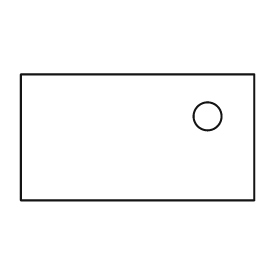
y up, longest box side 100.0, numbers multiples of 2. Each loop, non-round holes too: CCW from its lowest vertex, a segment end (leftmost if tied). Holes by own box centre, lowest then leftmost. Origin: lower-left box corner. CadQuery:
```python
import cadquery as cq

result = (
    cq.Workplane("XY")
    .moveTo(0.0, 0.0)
    .lineTo(100.0, 0.0)
    .lineTo(100.0, 54.0)
    .lineTo(0.0, 54.0)
    .close()
    .moveTo(80.0, 36.0)
    .circle(6.0)
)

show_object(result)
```